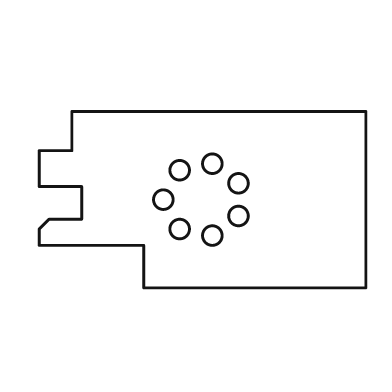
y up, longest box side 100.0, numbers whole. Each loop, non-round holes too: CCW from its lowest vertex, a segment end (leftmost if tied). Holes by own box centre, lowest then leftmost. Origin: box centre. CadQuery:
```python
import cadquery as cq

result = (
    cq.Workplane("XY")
    .moveTo(-18.0, -27.0)
    .lineTo(50.0, -27.0)
    .lineTo(50.0, 27.0)
    .lineTo(-40.0, 27.0)
    .lineTo(-40.0, 15.0)
    .lineTo(-50.0, 15.0)
    .lineTo(-50.0, 4.0)
    .lineTo(-37.0, 4.0)
    .lineTo(-37.0, -6.0)
    .lineTo(-47.0, -6.0)
    .lineTo(-50.0, -9.0)
    .lineTo(-50.0, -14.0)
    .lineTo(-18.0, -14.0)
    .close()
    .moveTo(3.0, -11.0)
    .circle(3.0)
    .moveTo(-7.0, -9.0)
    .circle(3.0)
    .moveTo(11.0, -5.0)
    .circle(3.0)
    .moveTo(-12.0, 0.0)
    .circle(3.0)
    .moveTo(11.0, 5.0)
    .circle(3.0)
    .moveTo(-7.0, 9.0)
    .circle(3.0)
    .moveTo(3.0, 11.0)
    .circle(3.0)
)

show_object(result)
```